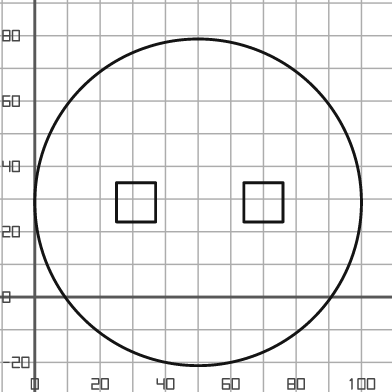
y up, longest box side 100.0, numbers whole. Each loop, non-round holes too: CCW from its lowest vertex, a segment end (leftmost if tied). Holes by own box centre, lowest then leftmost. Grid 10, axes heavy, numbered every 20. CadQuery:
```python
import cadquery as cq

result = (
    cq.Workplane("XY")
    .moveTo(50.0, 29.0)
    .circle(50.0)
    .moveTo(25.0, 23.0)
    .lineTo(37.0, 23.0)
    .lineTo(37.0, 35.0)
    .lineTo(25.0, 35.0)
    .close()
    .moveTo(64.0, 23.0)
    .lineTo(76.0, 23.0)
    .lineTo(76.0, 35.0)
    .lineTo(64.0, 35.0)
    .close()
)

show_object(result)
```